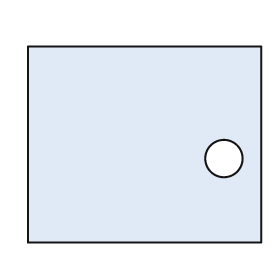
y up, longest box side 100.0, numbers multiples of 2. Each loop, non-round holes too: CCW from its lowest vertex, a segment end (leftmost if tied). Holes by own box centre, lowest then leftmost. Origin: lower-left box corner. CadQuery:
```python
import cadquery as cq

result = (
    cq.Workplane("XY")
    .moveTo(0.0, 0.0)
    .lineTo(100.0, 0.0)
    .lineTo(100.0, 84.0)
    .lineTo(0.0, 84.0)
    .close()
    .moveTo(84.0, 36.0)
    .circle(8.0)
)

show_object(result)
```